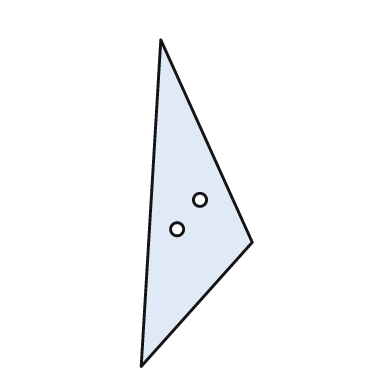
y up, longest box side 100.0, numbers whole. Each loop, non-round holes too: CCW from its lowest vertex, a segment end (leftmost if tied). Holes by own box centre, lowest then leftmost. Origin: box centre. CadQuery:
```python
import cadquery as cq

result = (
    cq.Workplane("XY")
    .moveTo(-17.0, -50.0)
    .lineTo(17.0, -12.0)
    .lineTo(-11.0, 50.0)
    .close()
    .moveTo(-6.0, -8.0)
    .circle(2.0)
    .moveTo(1.0, 1.0)
    .circle(2.0)
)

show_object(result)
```